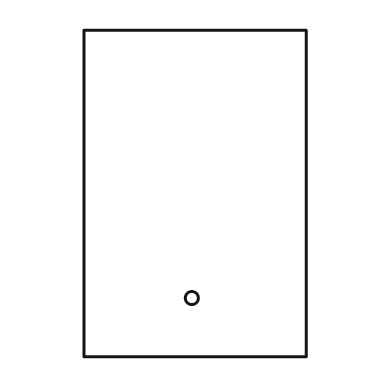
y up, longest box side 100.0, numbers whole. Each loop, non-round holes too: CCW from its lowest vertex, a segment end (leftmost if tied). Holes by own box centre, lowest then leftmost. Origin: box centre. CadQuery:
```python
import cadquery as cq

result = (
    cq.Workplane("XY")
    .moveTo(-34.0, -50.0)
    .lineTo(34.0, -50.0)
    .lineTo(34.0, 50.0)
    .lineTo(-34.0, 50.0)
    .close()
    .moveTo(-1.0, -32.0)
    .circle(2.0)
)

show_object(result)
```